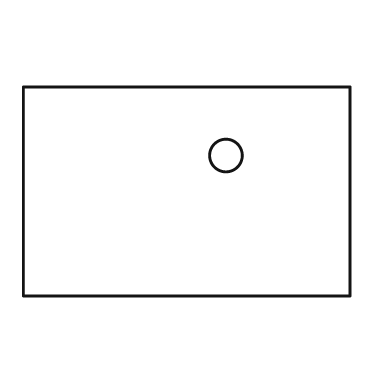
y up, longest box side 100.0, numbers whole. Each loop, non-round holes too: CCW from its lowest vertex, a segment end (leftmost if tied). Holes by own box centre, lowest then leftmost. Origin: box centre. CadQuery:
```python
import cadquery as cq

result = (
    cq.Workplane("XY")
    .moveTo(-50.0, -32.0)
    .lineTo(50.0, -32.0)
    .lineTo(50.0, 32.0)
    .lineTo(-50.0, 32.0)
    .close()
    .moveTo(12.0, 11.0)
    .circle(5.0)
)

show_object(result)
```